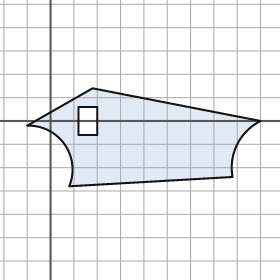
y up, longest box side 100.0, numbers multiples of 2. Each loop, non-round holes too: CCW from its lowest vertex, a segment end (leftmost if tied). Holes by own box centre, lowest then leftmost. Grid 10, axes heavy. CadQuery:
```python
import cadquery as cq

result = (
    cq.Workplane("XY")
    .moveTo(8.0, -28.0)
    .lineTo(78.0, -24.0)
    .threePointArc((80.0, -10.0), (90.0, 0.0))
    .lineTo(18.0, 14.0)
    .lineTo(-10.0, -2.0)
    .threePointArc((6.0, -10.0), (8.0, -28.0))
    .close()
    .moveTo(12.0, -6.0)
    .lineTo(20.0, -6.0)
    .lineTo(20.0, 6.0)
    .lineTo(12.0, 6.0)
    .close()
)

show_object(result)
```